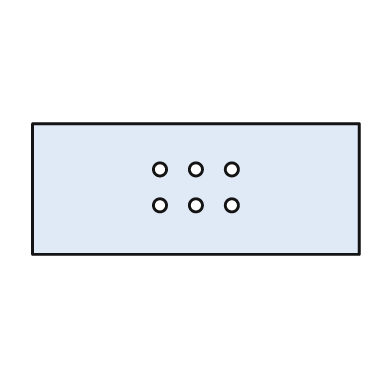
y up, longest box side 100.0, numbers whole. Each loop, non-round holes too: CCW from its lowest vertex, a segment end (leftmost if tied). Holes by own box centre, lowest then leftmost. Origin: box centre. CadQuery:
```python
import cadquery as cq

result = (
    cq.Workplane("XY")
    .moveTo(-50.0, -20.0)
    .lineTo(50.0, -20.0)
    .lineTo(50.0, 20.0)
    .lineTo(-50.0, 20.0)
    .close()
    .moveTo(-11.0, -5.0)
    .circle(2.0)
    .moveTo(0.0, -5.0)
    .circle(2.0)
    .moveTo(11.0, -5.0)
    .circle(2.0)
    .moveTo(-11.0, 6.0)
    .circle(2.0)
    .moveTo(0.0, 6.0)
    .circle(2.0)
    .moveTo(11.0, 6.0)
    .circle(2.0)
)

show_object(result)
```